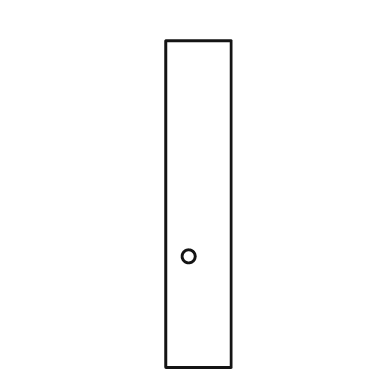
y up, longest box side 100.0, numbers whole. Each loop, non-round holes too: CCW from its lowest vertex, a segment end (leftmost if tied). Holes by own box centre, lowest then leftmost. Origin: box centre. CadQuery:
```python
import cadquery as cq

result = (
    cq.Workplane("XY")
    .moveTo(-10.0, -50.0)
    .lineTo(10.0, -50.0)
    .lineTo(10.0, 50.0)
    .lineTo(-10.0, 50.0)
    .close()
    .moveTo(-3.0, -16.0)
    .circle(2.0)
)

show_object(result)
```